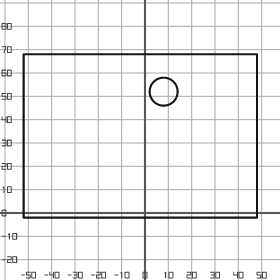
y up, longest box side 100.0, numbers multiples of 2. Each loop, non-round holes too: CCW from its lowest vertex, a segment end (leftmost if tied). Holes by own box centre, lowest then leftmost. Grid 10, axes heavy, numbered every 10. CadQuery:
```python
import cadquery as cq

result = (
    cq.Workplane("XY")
    .moveTo(-52.0, -2.0)
    .lineTo(48.0, -2.0)
    .lineTo(48.0, 68.0)
    .lineTo(-52.0, 68.0)
    .close()
    .moveTo(8.0, 52.0)
    .circle(6.0)
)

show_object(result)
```